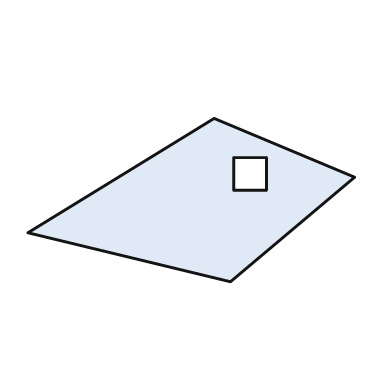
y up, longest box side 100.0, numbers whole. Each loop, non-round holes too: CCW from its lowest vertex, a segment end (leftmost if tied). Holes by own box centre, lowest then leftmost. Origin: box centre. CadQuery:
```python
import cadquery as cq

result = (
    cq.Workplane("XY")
    .moveTo(12.0, -25.0)
    .lineTo(50.0, 7.0)
    .lineTo(7.0, 25.0)
    .lineTo(-50.0, -10.0)
    .close()
    .moveTo(13.0, 3.0)
    .lineTo(23.0, 3.0)
    .lineTo(23.0, 13.0)
    .lineTo(13.0, 13.0)
    .close()
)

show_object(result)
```